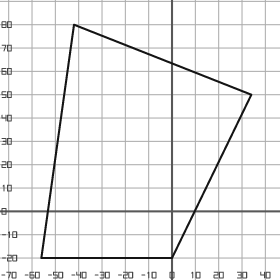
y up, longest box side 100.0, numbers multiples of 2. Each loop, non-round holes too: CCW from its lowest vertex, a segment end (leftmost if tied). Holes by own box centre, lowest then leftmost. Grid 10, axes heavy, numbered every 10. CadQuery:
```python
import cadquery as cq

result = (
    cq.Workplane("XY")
    .moveTo(-56.0, -20.0)
    .lineTo(0.0, -20.0)
    .lineTo(34.0, 50.0)
    .lineTo(-42.0, 80.0)
    .close()
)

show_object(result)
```